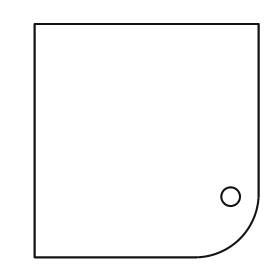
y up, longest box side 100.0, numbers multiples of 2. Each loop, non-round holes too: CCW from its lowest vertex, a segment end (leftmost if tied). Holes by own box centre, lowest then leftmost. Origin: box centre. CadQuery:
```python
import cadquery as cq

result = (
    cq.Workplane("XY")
    .moveTo(-48.0, -50.0)
    .lineTo(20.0, -50.0)
    .threePointArc((40.0, -42.0), (48.0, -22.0))
    .lineTo(48.0, 50.0)
    .lineTo(-48.0, 50.0)
    .close()
    .moveTo(36.0, -24.0)
    .circle(4.0)
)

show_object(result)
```